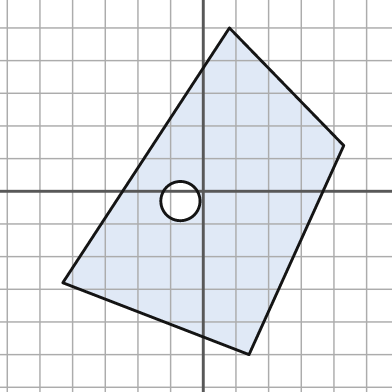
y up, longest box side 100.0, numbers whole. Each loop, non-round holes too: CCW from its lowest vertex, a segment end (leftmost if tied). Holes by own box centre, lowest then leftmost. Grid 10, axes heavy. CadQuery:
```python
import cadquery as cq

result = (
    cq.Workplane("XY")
    .moveTo(14.0, -50.0)
    .lineTo(43.0, 14.0)
    .lineTo(8.0, 50.0)
    .lineTo(-43.0, -28.0)
    .close()
    .moveTo(-7.0, -3.0)
    .circle(6.0)
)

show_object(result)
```